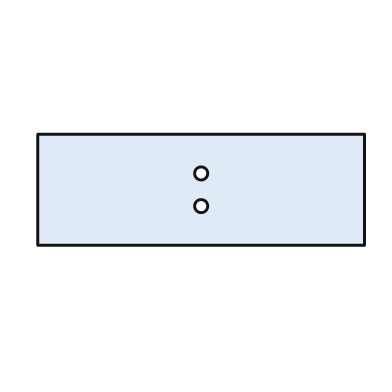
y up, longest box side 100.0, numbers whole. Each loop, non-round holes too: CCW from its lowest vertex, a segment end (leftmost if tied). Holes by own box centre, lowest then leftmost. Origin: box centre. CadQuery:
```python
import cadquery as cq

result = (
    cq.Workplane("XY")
    .moveTo(-50.0, -17.0)
    .lineTo(50.0, -17.0)
    .lineTo(50.0, 17.0)
    .lineTo(-50.0, 17.0)
    .close()
    .moveTo(0.0, -5.0)
    .circle(2.0)
    .moveTo(0.0, 5.0)
    .circle(2.0)
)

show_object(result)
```